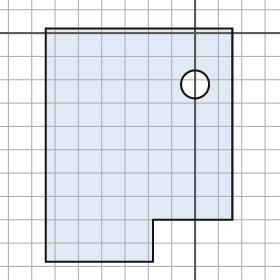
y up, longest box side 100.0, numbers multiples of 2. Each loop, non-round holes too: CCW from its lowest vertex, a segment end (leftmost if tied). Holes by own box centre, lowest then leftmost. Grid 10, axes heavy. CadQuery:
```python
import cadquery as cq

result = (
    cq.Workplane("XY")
    .moveTo(-64.0, -98.0)
    .lineTo(-18.0, -98.0)
    .lineTo(-18.0, -80.0)
    .lineTo(16.0, -80.0)
    .lineTo(16.0, 2.0)
    .lineTo(-64.0, 2.0)
    .close()
    .moveTo(0.0, -22.0)
    .circle(6.0)
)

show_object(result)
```